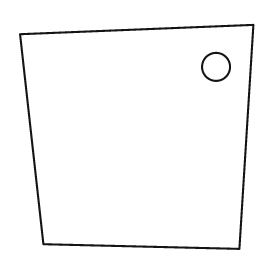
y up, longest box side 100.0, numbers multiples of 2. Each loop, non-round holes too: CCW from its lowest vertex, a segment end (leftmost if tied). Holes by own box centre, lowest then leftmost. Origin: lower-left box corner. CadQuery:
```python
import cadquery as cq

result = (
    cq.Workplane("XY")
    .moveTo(94.0, 0.0)
    .lineTo(100.0, 96.0)
    .lineTo(0.0, 92.0)
    .lineTo(10.0, 2.0)
    .close()
    .moveTo(84.0, 78.0)
    .circle(6.0)
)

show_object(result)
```